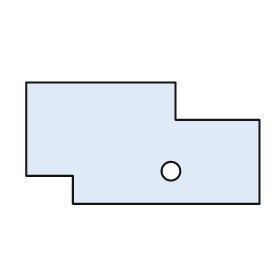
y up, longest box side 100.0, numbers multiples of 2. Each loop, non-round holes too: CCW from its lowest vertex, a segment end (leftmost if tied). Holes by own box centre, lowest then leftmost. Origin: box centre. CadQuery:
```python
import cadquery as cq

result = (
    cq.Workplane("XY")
    .moveTo(-30.0, -26.0)
    .lineTo(50.0, -26.0)
    .lineTo(50.0, 10.0)
    .lineTo(14.0, 10.0)
    .lineTo(14.0, 26.0)
    .lineTo(-50.0, 26.0)
    .lineTo(-50.0, -14.0)
    .lineTo(-30.0, -14.0)
    .close()
    .moveTo(12.0, -12.0)
    .circle(4.0)
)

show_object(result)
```